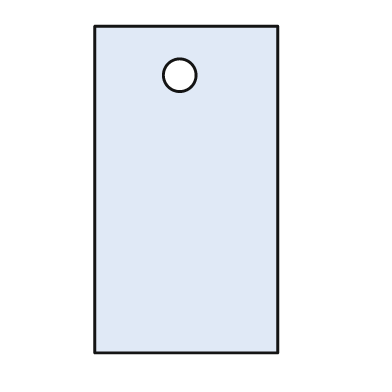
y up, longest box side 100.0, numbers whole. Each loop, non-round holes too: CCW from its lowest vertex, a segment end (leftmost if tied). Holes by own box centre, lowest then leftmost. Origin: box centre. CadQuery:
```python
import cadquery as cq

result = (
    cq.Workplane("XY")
    .moveTo(-28.0, -50.0)
    .lineTo(28.0, -50.0)
    .lineTo(28.0, 50.0)
    .lineTo(-28.0, 50.0)
    .close()
    .moveTo(-2.0, 35.0)
    .circle(5.0)
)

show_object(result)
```